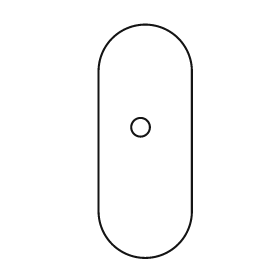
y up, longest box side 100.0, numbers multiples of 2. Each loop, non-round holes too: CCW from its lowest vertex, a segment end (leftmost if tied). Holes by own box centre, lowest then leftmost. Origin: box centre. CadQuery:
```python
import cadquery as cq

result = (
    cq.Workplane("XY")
    .moveTo(-20.0, -30.0)
    .threePointArc((0.0, -50.0), (20.0, -30.0))
    .lineTo(20.0, 30.0)
    .threePointArc((0.0, 50.0), (-20.0, 30.0))
    .close()
    .moveTo(-2.0, 6.0)
    .circle(4.0)
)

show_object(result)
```